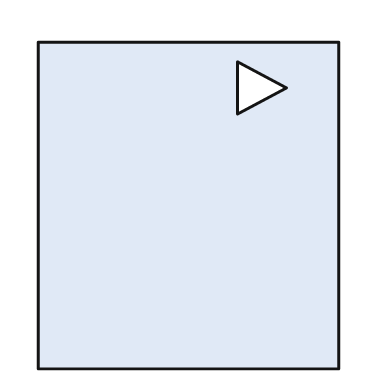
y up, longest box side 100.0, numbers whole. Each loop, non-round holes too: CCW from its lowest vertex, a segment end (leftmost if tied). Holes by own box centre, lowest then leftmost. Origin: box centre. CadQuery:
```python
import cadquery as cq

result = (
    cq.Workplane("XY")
    .moveTo(-46.0, -50.0)
    .lineTo(46.0, -50.0)
    .lineTo(46.0, 50.0)
    .lineTo(-46.0, 50.0)
    .close()
    .moveTo(15.0, 28.0)
    .lineTo(30.0, 36.0)
    .lineTo(15.0, 44.0)
    .close()
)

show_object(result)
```